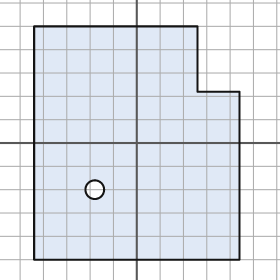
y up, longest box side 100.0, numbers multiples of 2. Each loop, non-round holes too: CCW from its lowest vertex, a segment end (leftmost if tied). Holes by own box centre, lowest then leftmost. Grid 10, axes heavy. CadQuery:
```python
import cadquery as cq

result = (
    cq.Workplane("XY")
    .moveTo(-44.0, -50.0)
    .lineTo(44.0, -50.0)
    .lineTo(44.0, 22.0)
    .lineTo(26.0, 22.0)
    .lineTo(26.0, 50.0)
    .lineTo(-44.0, 50.0)
    .close()
    .moveTo(-18.0, -20.0)
    .circle(4.0)
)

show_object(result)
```